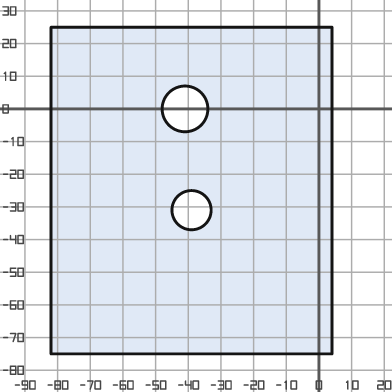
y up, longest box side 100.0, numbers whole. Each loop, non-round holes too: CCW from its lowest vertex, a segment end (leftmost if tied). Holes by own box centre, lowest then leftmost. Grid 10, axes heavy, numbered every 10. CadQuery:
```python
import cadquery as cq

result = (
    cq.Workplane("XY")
    .moveTo(-82.0, -75.0)
    .lineTo(4.0, -75.0)
    .lineTo(4.0, 25.0)
    .lineTo(-82.0, 25.0)
    .close()
    .moveTo(-39.0, -31.0)
    .circle(6.0)
    .moveTo(-41.0, 0.0)
    .circle(7.0)
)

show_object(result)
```